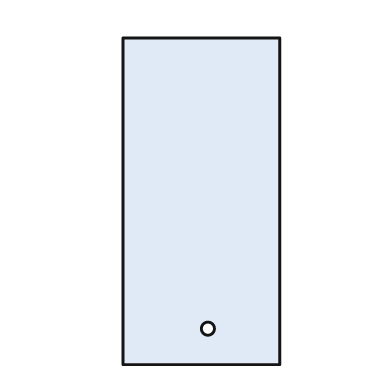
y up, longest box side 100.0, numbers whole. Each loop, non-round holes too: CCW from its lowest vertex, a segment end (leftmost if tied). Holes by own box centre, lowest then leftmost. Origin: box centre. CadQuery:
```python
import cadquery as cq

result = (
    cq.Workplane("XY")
    .moveTo(-24.0, -50.0)
    .lineTo(24.0, -50.0)
    .lineTo(24.0, 50.0)
    .lineTo(-24.0, 50.0)
    .close()
    .moveTo(2.0, -39.0)
    .circle(2.0)
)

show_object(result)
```